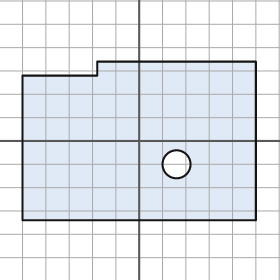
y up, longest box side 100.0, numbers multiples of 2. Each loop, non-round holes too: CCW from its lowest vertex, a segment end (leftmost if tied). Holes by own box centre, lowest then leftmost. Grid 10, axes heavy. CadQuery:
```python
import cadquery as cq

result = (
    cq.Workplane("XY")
    .moveTo(-50.0, -34.0)
    .lineTo(50.0, -34.0)
    .lineTo(50.0, 34.0)
    .lineTo(-18.0, 34.0)
    .lineTo(-18.0, 28.0)
    .lineTo(-50.0, 28.0)
    .close()
    .moveTo(16.0, -10.0)
    .circle(6.0)
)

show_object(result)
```